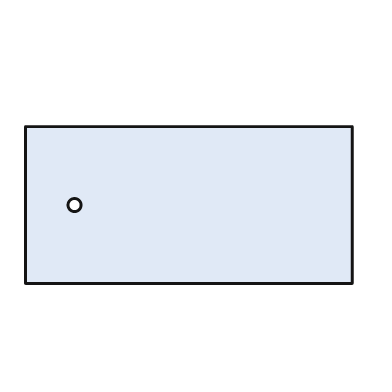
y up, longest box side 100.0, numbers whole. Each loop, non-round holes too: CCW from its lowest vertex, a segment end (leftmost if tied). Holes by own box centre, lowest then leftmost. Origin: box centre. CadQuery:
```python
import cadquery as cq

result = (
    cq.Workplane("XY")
    .moveTo(-50.0, -24.0)
    .lineTo(50.0, -24.0)
    .lineTo(50.0, 24.0)
    .lineTo(-50.0, 24.0)
    .close()
    .moveTo(-35.0, 0.0)
    .circle(2.0)
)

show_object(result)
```